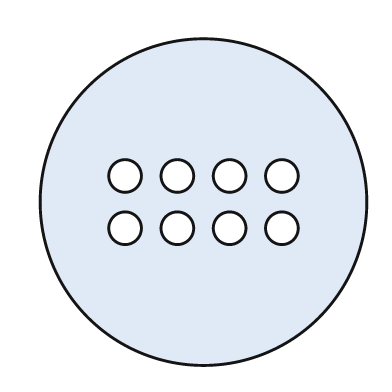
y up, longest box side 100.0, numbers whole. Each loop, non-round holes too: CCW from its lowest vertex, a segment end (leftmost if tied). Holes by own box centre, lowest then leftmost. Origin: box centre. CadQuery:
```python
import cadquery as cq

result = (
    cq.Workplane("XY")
    .moveTo(0.0, 0.0)
    .circle(50.0)
    .moveTo(-24.0, -8.0)
    .circle(5.0)
    .moveTo(-8.0, -8.0)
    .circle(5.0)
    .moveTo(8.0, -8.0)
    .circle(5.0)
    .moveTo(24.0, -8.0)
    .circle(5.0)
    .moveTo(-24.0, 8.0)
    .circle(5.0)
    .moveTo(-8.0, 8.0)
    .circle(5.0)
    .moveTo(8.0, 8.0)
    .circle(5.0)
    .moveTo(24.0, 8.0)
    .circle(5.0)
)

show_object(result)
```